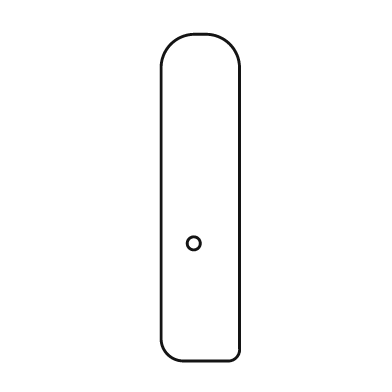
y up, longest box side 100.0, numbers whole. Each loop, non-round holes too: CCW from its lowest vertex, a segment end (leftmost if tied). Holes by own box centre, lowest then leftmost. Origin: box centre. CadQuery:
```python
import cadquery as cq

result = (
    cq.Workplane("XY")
    .moveTo(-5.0, -50.0)
    .lineTo(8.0, -50.0)
    .threePointArc((11.0, -49.0), (12.0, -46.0))
    .lineTo(12.0, 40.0)
    .threePointArc((9.0, 47.0), (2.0, 50.0))
    .lineTo(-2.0, 50.0)
    .threePointArc((-9.0, 47.0), (-12.0, 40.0))
    .lineTo(-12.0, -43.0)
    .threePointArc((-10.0, -48.0), (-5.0, -50.0))
    .close()
    .moveTo(-2.0, -14.0)
    .circle(2.0)
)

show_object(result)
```